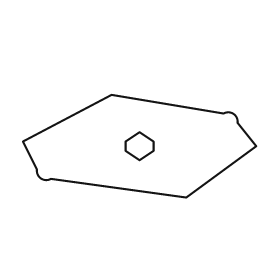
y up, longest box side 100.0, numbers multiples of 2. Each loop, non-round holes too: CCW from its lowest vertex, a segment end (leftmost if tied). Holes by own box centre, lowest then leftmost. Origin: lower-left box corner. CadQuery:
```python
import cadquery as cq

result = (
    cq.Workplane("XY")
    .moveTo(70.0, 0.0)
    .lineTo(100.0, 22.0)
    .lineTo(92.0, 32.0)
    .threePointArc((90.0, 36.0), (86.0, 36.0))
    .lineTo(38.0, 44.0)
    .lineTo(0.0, 24.0)
    .lineTo(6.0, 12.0)
    .threePointArc((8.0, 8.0), (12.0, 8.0))
    .close()
    .moveTo(50.0, 16.0)
    .lineTo(56.0, 20.0)
    .lineTo(56.0, 24.0)
    .lineTo(50.0, 28.0)
    .lineTo(44.0, 24.0)
    .lineTo(44.0, 20.0)
    .close()
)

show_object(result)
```